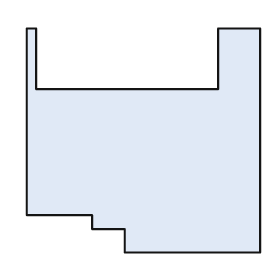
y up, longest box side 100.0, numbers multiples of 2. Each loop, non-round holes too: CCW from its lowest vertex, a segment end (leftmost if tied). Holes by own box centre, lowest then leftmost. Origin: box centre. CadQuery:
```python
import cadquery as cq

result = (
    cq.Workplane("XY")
    .moveTo(-8.0, -48.0)
    .lineTo(50.0, -48.0)
    .lineTo(50.0, 48.0)
    .lineTo(32.0, 48.0)
    .lineTo(32.0, 22.0)
    .lineTo(-46.0, 22.0)
    .lineTo(-46.0, 48.0)
    .lineTo(-50.0, 48.0)
    .lineTo(-50.0, -32.0)
    .lineTo(-22.0, -32.0)
    .lineTo(-22.0, -38.0)
    .lineTo(-8.0, -38.0)
    .close()
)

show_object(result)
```